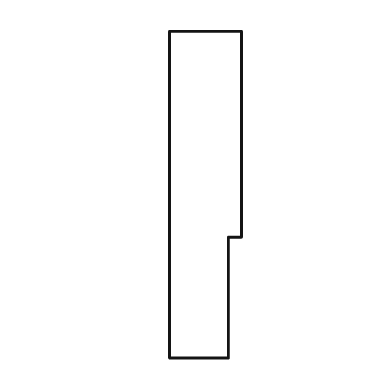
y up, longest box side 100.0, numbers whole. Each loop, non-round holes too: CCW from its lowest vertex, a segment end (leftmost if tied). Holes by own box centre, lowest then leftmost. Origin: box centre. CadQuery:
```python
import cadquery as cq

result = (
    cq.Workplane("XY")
    .moveTo(-11.0, -50.0)
    .lineTo(7.0, -50.0)
    .lineTo(7.0, -13.0)
    .lineTo(11.0, -13.0)
    .lineTo(11.0, 50.0)
    .lineTo(-11.0, 50.0)
    .close()
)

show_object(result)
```